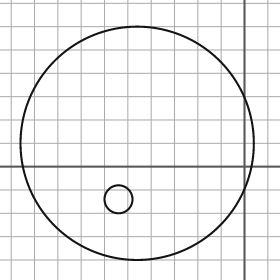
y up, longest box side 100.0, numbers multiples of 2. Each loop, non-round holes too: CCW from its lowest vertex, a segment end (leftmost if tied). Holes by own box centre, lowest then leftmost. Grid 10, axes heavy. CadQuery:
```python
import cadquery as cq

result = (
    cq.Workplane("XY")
    .moveTo(-46.0, 10.0)
    .circle(50.0)
    .moveTo(-54.0, -14.0)
    .circle(6.0)
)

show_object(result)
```